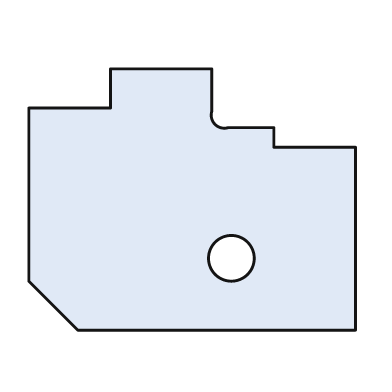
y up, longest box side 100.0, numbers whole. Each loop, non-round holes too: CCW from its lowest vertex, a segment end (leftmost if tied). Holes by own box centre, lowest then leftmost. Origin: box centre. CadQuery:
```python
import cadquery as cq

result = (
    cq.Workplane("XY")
    .moveTo(-35.0, -40.0)
    .lineTo(50.0, -40.0)
    .lineTo(50.0, 16.0)
    .lineTo(25.0, 16.0)
    .lineTo(25.0, 22.0)
    .lineTo(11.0, 22.0)
    .threePointArc((7.0, 23.0), (6.0, 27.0))
    .lineTo(6.0, 40.0)
    .lineTo(-25.0, 40.0)
    .lineTo(-25.0, 28.0)
    .lineTo(-50.0, 28.0)
    .lineTo(-50.0, -25.0)
    .close()
    .moveTo(12.0, -18.0)
    .circle(7.0)
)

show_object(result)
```